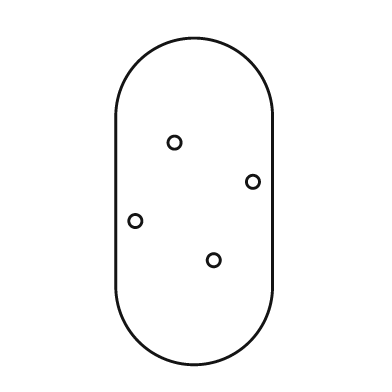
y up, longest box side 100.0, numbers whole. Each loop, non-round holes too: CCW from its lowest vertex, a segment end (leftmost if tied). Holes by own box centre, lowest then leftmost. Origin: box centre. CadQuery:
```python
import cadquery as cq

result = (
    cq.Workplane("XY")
    .moveTo(-24.0, -26.0)
    .threePointArc((0.0, -50.0), (24.0, -26.0))
    .lineTo(24.0, 26.0)
    .threePointArc((0.0, 50.0), (-24.0, 26.0))
    .close()
    .moveTo(6.0, -18.0)
    .circle(2.0)
    .moveTo(-18.0, -6.0)
    .circle(2.0)
    .moveTo(18.0, 6.0)
    .circle(2.0)
    .moveTo(-6.0, 18.0)
    .circle(2.0)
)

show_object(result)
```